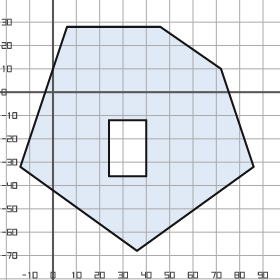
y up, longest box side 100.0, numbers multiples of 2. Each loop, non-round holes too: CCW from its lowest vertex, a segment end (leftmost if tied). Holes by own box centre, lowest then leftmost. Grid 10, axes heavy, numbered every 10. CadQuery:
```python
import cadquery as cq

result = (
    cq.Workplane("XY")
    .moveTo(36.0, -68.0)
    .lineTo(86.0, -32.0)
    .lineTo(72.0, 10.0)
    .lineTo(46.0, 28.0)
    .lineTo(6.0, 28.0)
    .lineTo(-14.0, -32.0)
    .close()
    .moveTo(24.0, -36.0)
    .lineTo(40.0, -36.0)
    .lineTo(40.0, -12.0)
    .lineTo(24.0, -12.0)
    .close()
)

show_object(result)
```